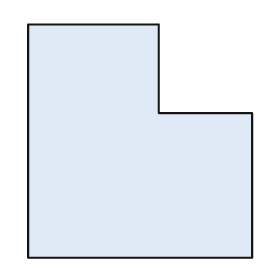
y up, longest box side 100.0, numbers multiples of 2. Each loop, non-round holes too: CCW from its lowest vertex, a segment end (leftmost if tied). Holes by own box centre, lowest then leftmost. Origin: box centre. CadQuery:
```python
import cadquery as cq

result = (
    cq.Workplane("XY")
    .moveTo(-48.0, -50.0)
    .lineTo(48.0, -50.0)
    .lineTo(48.0, 12.0)
    .lineTo(8.0, 12.0)
    .lineTo(8.0, 50.0)
    .lineTo(-48.0, 50.0)
    .close()
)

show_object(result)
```